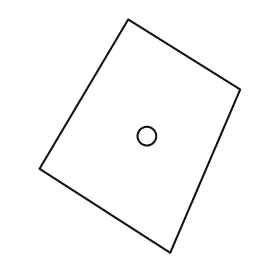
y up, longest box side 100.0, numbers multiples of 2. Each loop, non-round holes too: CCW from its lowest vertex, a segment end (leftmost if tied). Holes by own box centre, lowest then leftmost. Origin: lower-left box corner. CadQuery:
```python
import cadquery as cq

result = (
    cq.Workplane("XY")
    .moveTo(56.0, 0.0)
    .lineTo(86.0, 70.0)
    .lineTo(38.0, 100.0)
    .lineTo(0.0, 36.0)
    .close()
    .moveTo(46.0, 50.0)
    .circle(4.0)
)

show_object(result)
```